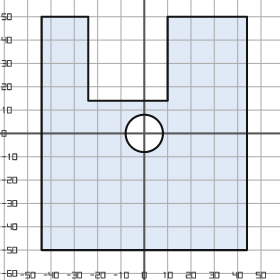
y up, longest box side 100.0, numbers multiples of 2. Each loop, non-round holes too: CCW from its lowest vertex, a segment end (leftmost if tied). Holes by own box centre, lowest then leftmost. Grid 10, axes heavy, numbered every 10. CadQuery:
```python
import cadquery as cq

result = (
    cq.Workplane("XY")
    .moveTo(-44.0, -50.0)
    .lineTo(44.0, -50.0)
    .lineTo(44.0, 50.0)
    .lineTo(10.0, 50.0)
    .lineTo(10.0, 14.0)
    .lineTo(-24.0, 14.0)
    .lineTo(-24.0, 50.0)
    .lineTo(-44.0, 50.0)
    .close()
    .moveTo(0.0, 0.0)
    .circle(8.0)
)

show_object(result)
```